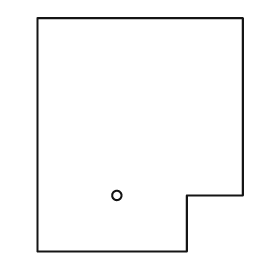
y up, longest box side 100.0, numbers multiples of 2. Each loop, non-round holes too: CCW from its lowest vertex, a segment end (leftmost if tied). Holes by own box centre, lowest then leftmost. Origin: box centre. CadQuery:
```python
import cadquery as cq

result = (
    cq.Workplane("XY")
    .moveTo(-44.0, -50.0)
    .lineTo(20.0, -50.0)
    .lineTo(20.0, -26.0)
    .lineTo(44.0, -26.0)
    .lineTo(44.0, 50.0)
    .lineTo(-44.0, 50.0)
    .close()
    .moveTo(-10.0, -26.0)
    .circle(2.0)
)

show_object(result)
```